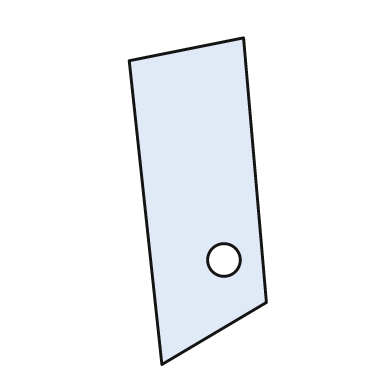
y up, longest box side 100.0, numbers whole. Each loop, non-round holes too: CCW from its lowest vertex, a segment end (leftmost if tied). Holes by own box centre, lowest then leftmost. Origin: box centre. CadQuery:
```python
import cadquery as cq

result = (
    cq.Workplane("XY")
    .moveTo(-11.0, -50.0)
    .lineTo(21.0, -31.0)
    .lineTo(14.0, 50.0)
    .lineTo(-21.0, 43.0)
    .close()
    .moveTo(8.0, -18.0)
    .circle(5.0)
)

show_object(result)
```